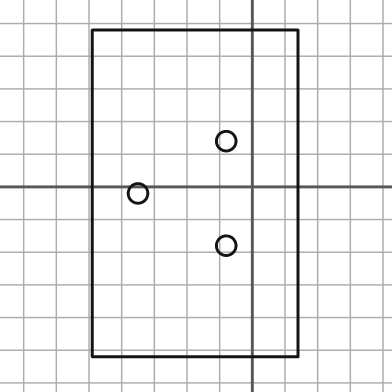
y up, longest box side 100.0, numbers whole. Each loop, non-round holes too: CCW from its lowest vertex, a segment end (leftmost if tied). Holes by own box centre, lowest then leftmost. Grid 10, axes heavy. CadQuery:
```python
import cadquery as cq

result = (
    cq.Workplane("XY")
    .moveTo(-49.0, -52.0)
    .lineTo(14.0, -52.0)
    .lineTo(14.0, 48.0)
    .lineTo(-49.0, 48.0)
    .close()
    .moveTo(-8.0, -18.0)
    .circle(3.0)
    .moveTo(-35.0, -2.0)
    .circle(3.0)
    .moveTo(-8.0, 14.0)
    .circle(3.0)
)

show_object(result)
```